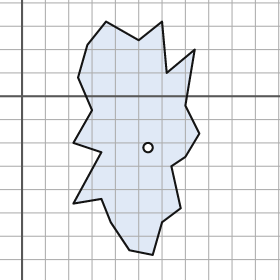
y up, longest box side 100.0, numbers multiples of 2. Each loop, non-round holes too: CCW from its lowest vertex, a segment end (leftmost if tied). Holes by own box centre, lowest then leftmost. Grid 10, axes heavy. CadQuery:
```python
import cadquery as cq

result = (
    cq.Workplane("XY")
    .moveTo(56.0, -68.0)
    .lineTo(60.0, -54.0)
    .lineTo(68.0, -48.0)
    .lineTo(64.0, -30.0)
    .lineTo(70.0, -26.0)
    .lineTo(76.0, -16.0)
    .lineTo(70.0, -4.0)
    .lineTo(74.0, 20.0)
    .lineTo(62.0, 10.0)
    .lineTo(60.0, 32.0)
    .lineTo(50.0, 24.0)
    .lineTo(36.0, 32.0)
    .lineTo(28.0, 22.0)
    .lineTo(24.0, 8.0)
    .lineTo(30.0, -6.0)
    .lineTo(22.0, -20.0)
    .lineTo(34.0, -24.0)
    .lineTo(22.0, -46.0)
    .lineTo(34.0, -44.0)
    .lineTo(38.0, -54.0)
    .lineTo(46.0, -66.0)
    .close()
    .moveTo(54.0, -22.0)
    .circle(2.0)
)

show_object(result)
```